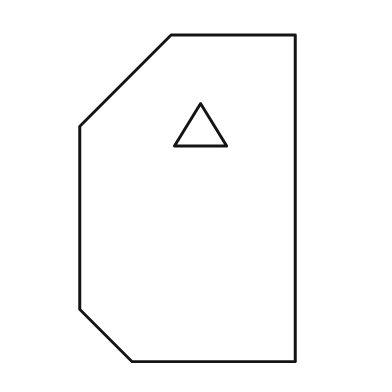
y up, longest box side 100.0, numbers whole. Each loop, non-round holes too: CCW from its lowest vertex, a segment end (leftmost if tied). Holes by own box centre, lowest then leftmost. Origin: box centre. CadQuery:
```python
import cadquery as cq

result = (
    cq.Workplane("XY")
    .moveTo(-17.0, -50.0)
    .lineTo(33.0, -50.0)
    .lineTo(33.0, 50.0)
    .lineTo(-5.0, 50.0)
    .lineTo(-33.0, 22.0)
    .lineTo(-33.0, -34.0)
    .close()
    .moveTo(-4.0, 16.0)
    .lineTo(12.0, 16.0)
    .lineTo(4.0, 29.0)
    .close()
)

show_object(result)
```